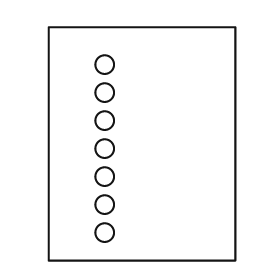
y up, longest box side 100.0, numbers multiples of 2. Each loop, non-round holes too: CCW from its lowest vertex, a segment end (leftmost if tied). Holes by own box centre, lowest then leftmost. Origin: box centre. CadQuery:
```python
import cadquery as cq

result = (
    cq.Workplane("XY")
    .moveTo(-40.0, -50.0)
    .lineTo(40.0, -50.0)
    .lineTo(40.0, 50.0)
    .lineTo(-40.0, 50.0)
    .close()
    .moveTo(-16.0, -38.0)
    .circle(4.0)
    .moveTo(-16.0, -26.0)
    .circle(4.0)
    .moveTo(-16.0, -14.0)
    .circle(4.0)
    .moveTo(-16.0, -2.0)
    .circle(4.0)
    .moveTo(-16.0, 10.0)
    .circle(4.0)
    .moveTo(-16.0, 22.0)
    .circle(4.0)
    .moveTo(-16.0, 34.0)
    .circle(4.0)
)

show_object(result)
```